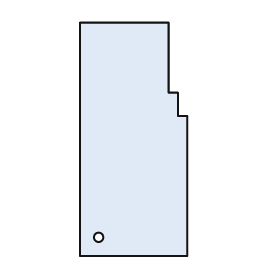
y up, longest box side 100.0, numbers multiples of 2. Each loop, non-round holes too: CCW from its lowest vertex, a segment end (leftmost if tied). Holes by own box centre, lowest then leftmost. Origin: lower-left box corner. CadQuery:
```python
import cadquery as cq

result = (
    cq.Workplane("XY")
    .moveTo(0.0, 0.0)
    .lineTo(46.0, 0.0)
    .lineTo(46.0, 60.0)
    .lineTo(42.0, 60.0)
    .lineTo(42.0, 70.0)
    .lineTo(38.0, 70.0)
    .lineTo(38.0, 100.0)
    .lineTo(0.0, 100.0)
    .close()
    .moveTo(8.0, 8.0)
    .circle(2.0)
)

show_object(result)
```